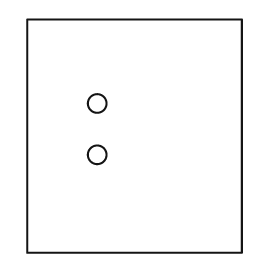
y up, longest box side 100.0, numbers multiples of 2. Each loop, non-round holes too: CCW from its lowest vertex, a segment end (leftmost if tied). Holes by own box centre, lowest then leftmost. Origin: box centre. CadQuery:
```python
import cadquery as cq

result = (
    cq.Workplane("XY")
    .moveTo(-46.0, -50.0)
    .lineTo(46.0, -50.0)
    .lineTo(46.0, 50.0)
    .lineTo(-46.0, 50.0)
    .close()
    .moveTo(-16.0, -8.0)
    .circle(4.0)
    .moveTo(-16.0, 14.0)
    .circle(4.0)
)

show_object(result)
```